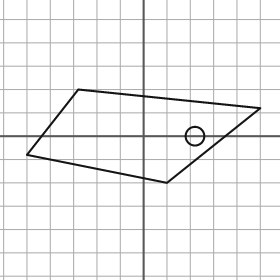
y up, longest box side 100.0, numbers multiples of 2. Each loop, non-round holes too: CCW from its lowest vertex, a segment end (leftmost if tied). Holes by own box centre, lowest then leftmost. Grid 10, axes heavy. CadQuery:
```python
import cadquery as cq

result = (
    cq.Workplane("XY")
    .moveTo(10.0, -20.0)
    .lineTo(50.0, 12.0)
    .lineTo(-28.0, 20.0)
    .lineTo(-50.0, -8.0)
    .close()
    .moveTo(22.0, 0.0)
    .circle(4.0)
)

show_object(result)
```